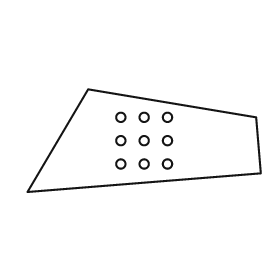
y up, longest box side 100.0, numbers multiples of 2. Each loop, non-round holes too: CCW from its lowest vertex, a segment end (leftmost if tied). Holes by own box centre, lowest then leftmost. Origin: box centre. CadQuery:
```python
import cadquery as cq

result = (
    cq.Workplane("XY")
    .moveTo(-50.0, -22.0)
    .lineTo(50.0, -14.0)
    .lineTo(48.0, 10.0)
    .lineTo(-24.0, 22.0)
    .close()
    .moveTo(-10.0, -10.0)
    .circle(2.0)
    .moveTo(0.0, -10.0)
    .circle(2.0)
    .moveTo(10.0, -10.0)
    .circle(2.0)
    .moveTo(-10.0, 0.0)
    .circle(2.0)
    .moveTo(0.0, 0.0)
    .circle(2.0)
    .moveTo(10.0, 0.0)
    .circle(2.0)
    .moveTo(-10.0, 10.0)
    .circle(2.0)
    .moveTo(0.0, 10.0)
    .circle(2.0)
    .moveTo(10.0, 10.0)
    .circle(2.0)
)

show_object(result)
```